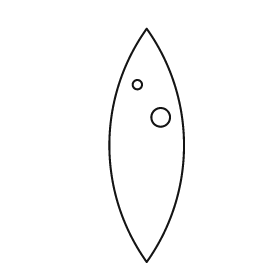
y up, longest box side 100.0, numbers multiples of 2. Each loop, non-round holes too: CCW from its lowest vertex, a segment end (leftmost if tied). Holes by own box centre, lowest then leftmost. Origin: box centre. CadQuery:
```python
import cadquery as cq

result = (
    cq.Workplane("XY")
    .moveTo(0.0, -50.0)
    .threePointArc((16.0, 0.0), (0.0, 50.0))
    .threePointArc((-16.0, 0.0), (0.0, -50.0))
    .close()
    .moveTo(6.0, 12.0)
    .circle(4.0)
    .moveTo(-4.0, 26.0)
    .circle(2.0)
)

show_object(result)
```